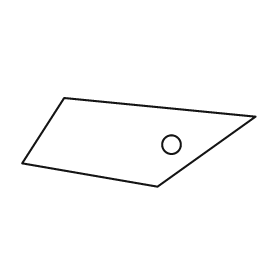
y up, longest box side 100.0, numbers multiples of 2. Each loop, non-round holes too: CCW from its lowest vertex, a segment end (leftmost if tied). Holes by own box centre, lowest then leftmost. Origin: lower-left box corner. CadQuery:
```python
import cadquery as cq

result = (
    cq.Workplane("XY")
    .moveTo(58.0, 0.0)
    .lineTo(100.0, 30.0)
    .lineTo(18.0, 38.0)
    .lineTo(0.0, 10.0)
    .close()
    .moveTo(64.0, 18.0)
    .circle(4.0)
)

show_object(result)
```